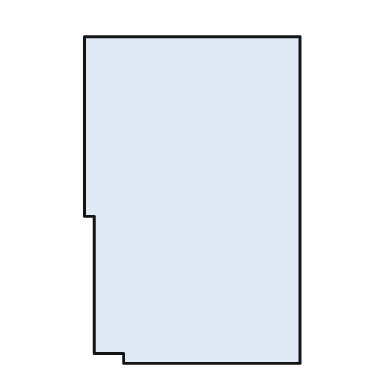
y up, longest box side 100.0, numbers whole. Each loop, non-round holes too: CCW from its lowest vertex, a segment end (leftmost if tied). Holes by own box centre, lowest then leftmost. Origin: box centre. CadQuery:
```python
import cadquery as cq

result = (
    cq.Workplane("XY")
    .moveTo(-21.0, -50.0)
    .lineTo(33.0, -50.0)
    .lineTo(33.0, 50.0)
    .lineTo(-33.0, 50.0)
    .lineTo(-33.0, -5.0)
    .lineTo(-30.0, -5.0)
    .lineTo(-30.0, -47.0)
    .lineTo(-21.0, -47.0)
    .close()
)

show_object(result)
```